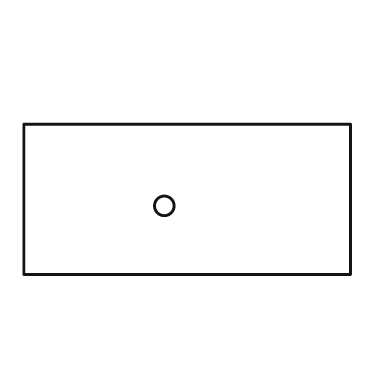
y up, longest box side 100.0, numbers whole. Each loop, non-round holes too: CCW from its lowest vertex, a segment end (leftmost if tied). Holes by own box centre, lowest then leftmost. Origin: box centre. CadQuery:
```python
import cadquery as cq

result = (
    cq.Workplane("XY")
    .moveTo(-50.0, -23.0)
    .lineTo(50.0, -23.0)
    .lineTo(50.0, 23.0)
    .lineTo(-50.0, 23.0)
    .close()
    .moveTo(-7.0, -2.0)
    .circle(3.0)
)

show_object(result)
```